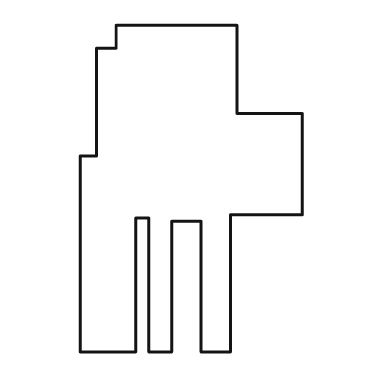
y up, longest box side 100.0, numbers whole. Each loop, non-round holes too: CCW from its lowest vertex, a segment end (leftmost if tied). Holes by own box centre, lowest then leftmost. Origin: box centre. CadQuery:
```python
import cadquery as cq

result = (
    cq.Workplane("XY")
    .moveTo(-34.0, -50.0)
    .lineTo(-17.0, -50.0)
    .lineTo(-17.0, -9.0)
    .lineTo(-13.0, -9.0)
    .lineTo(-13.0, -50.0)
    .lineTo(-6.0, -50.0)
    .lineTo(-6.0, -10.0)
    .lineTo(3.0, -10.0)
    .lineTo(3.0, -50.0)
    .lineTo(12.0, -50.0)
    .lineTo(12.0, -8.0)
    .lineTo(34.0, -8.0)
    .lineTo(34.0, 23.0)
    .lineTo(14.0, 23.0)
    .lineTo(14.0, 50.0)
    .lineTo(-23.0, 50.0)
    .lineTo(-23.0, 43.0)
    .lineTo(-29.0, 43.0)
    .lineTo(-29.0, 10.0)
    .lineTo(-34.0, 10.0)
    .close()
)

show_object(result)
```